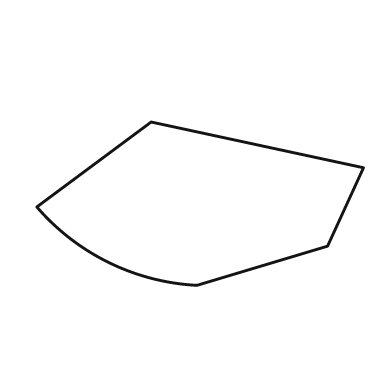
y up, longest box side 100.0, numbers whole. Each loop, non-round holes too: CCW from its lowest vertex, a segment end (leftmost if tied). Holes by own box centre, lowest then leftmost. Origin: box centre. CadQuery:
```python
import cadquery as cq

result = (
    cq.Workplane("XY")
    .moveTo(-1.0, -25.0)
    .lineTo(39.0, -13.0)
    .lineTo(50.0, 11.0)
    .lineTo(-15.0, 25.0)
    .lineTo(-50.0, -1.0)
    .threePointArc((-28.0, -18.0), (-1.0, -25.0))
    .close()
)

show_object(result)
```